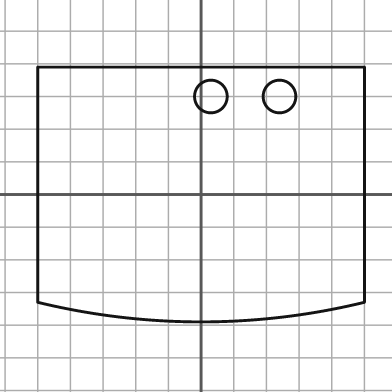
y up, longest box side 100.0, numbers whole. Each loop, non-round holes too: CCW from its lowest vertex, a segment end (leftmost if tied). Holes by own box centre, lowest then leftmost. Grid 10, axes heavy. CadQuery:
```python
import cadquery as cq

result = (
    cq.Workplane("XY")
    .moveTo(-50.0, -33.0)
    .threePointArc((0.0, -39.0), (50.0, -33.0))
    .lineTo(50.0, 39.0)
    .lineTo(-50.0, 39.0)
    .close()
    .moveTo(3.0, 30.0)
    .circle(5.0)
    .moveTo(24.0, 30.0)
    .circle(5.0)
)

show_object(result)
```